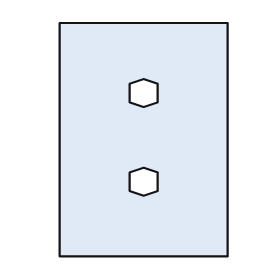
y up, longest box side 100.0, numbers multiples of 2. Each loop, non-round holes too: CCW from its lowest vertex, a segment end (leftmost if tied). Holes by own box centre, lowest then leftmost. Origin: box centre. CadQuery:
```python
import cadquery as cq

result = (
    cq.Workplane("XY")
    .moveTo(-36.0, -50.0)
    .lineTo(36.0, -50.0)
    .lineTo(36.0, 50.0)
    .lineTo(-36.0, 50.0)
    .close()
    .moveTo(0.0, -24.0)
    .lineTo(6.0, -22.0)
    .lineTo(6.0, -14.0)
    .lineTo(0.0, -12.0)
    .lineTo(-6.0, -14.0)
    .lineTo(-6.0, -22.0)
    .close()
    .moveTo(0.0, 14.0)
    .lineTo(6.0, 16.0)
    .lineTo(6.0, 24.0)
    .lineTo(0.0, 26.0)
    .lineTo(-6.0, 24.0)
    .lineTo(-6.0, 16.0)
    .close()
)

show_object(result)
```